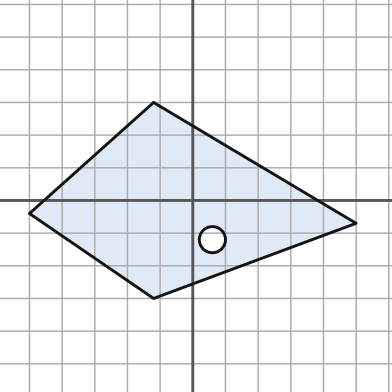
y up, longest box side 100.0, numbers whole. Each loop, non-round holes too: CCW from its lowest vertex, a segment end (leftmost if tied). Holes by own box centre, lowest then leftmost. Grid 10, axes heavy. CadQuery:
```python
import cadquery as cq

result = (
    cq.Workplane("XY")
    .moveTo(-12.0, -30.0)
    .lineTo(50.0, -7.0)
    .lineTo(-12.0, 30.0)
    .lineTo(-50.0, -4.0)
    .close()
    .moveTo(6.0, -12.0)
    .circle(4.0)
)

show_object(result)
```